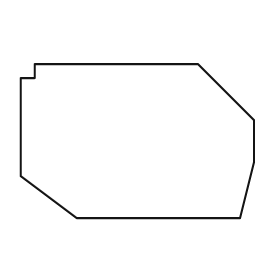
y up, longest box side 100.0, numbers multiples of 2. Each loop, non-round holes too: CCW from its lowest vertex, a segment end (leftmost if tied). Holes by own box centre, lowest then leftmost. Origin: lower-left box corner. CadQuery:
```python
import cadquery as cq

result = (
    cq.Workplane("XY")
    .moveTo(24.0, 0.0)
    .lineTo(94.0, 0.0)
    .lineTo(100.0, 24.0)
    .lineTo(100.0, 42.0)
    .lineTo(76.0, 66.0)
    .lineTo(6.0, 66.0)
    .lineTo(6.0, 60.0)
    .lineTo(0.0, 60.0)
    .lineTo(0.0, 18.0)
    .close()
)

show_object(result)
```